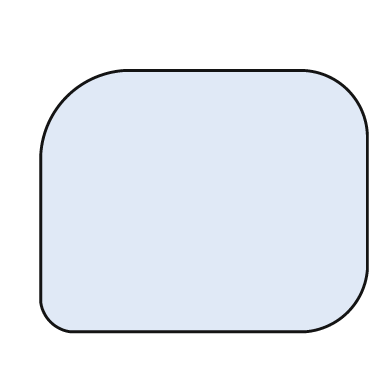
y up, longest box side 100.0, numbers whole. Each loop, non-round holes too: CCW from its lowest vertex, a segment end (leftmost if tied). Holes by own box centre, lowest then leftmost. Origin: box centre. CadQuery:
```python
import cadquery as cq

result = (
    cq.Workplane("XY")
    .moveTo(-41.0, -40.0)
    .lineTo(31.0, -40.0)
    .threePointArc((44.0, -34.0), (50.0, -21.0))
    .lineTo(50.0, 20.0)
    .threePointArc((44.0, 34.0), (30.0, 40.0))
    .lineTo(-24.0, 40.0)
    .threePointArc((-42.0, 32.0), (-50.0, 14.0))
    .lineTo(-50.0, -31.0)
    .threePointArc((-47.0, -37.0), (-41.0, -40.0))
    .close()
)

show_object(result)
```